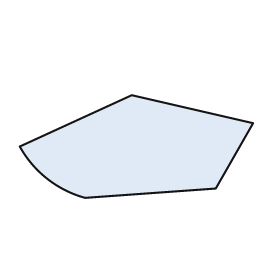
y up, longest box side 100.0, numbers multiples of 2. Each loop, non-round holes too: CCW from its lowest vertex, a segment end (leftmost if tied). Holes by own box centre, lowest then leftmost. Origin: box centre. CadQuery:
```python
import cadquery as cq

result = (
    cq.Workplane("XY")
    .moveTo(-22.0, -22.0)
    .lineTo(34.0, -18.0)
    .lineTo(50.0, 10.0)
    .lineTo(-2.0, 22.0)
    .lineTo(-50.0, 0.0)
    .threePointArc((-38.0, -14.0), (-22.0, -22.0))
    .close()
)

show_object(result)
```